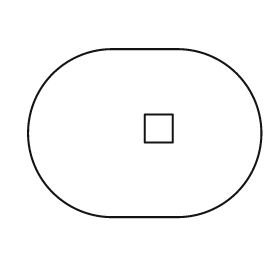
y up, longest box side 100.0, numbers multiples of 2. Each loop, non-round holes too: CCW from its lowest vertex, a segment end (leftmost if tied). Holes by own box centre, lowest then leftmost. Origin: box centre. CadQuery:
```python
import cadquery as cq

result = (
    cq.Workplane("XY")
    .moveTo(-14.0, -36.0)
    .lineTo(14.0, -36.0)
    .threePointArc((50.0, 0.0), (14.0, 36.0))
    .lineTo(-14.0, 36.0)
    .threePointArc((-50.0, 0.0), (-14.0, -36.0))
    .close()
    .moveTo(0.0, -4.0)
    .lineTo(12.0, -4.0)
    .lineTo(12.0, 8.0)
    .lineTo(0.0, 8.0)
    .close()
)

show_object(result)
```